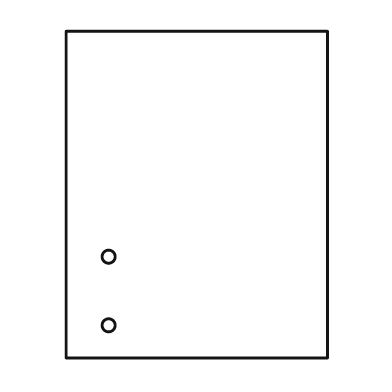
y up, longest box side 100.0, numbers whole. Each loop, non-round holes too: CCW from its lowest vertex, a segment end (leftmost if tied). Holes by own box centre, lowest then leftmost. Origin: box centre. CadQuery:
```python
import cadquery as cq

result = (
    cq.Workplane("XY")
    .moveTo(-40.0, -50.0)
    .lineTo(40.0, -50.0)
    .lineTo(40.0, 50.0)
    .lineTo(-40.0, 50.0)
    .close()
    .moveTo(-27.0, -40.0)
    .circle(2.0)
    .moveTo(-27.0, -19.0)
    .circle(2.0)
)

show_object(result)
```